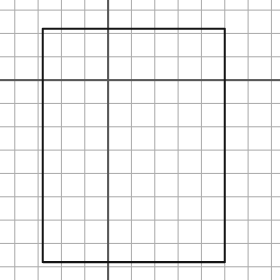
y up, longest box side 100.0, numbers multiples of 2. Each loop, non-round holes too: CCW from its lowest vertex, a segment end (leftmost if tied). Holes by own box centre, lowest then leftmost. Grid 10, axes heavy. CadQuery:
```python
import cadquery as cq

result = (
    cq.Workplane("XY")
    .moveTo(-28.0, -78.0)
    .lineTo(50.0, -78.0)
    .lineTo(50.0, 22.0)
    .lineTo(-28.0, 22.0)
    .close()
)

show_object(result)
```